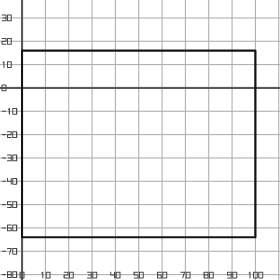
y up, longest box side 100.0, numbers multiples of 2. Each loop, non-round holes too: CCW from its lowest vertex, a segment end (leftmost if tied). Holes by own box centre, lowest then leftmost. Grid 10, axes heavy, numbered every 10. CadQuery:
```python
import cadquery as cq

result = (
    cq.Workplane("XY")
    .moveTo(0.0, -64.0)
    .lineTo(100.0, -64.0)
    .lineTo(100.0, 16.0)
    .lineTo(0.0, 16.0)
    .close()
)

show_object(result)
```